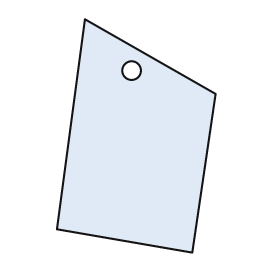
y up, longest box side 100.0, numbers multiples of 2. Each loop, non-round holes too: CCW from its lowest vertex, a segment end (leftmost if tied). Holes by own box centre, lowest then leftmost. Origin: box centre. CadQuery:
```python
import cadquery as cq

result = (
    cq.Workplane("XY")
    .moveTo(24.0, -50.0)
    .lineTo(34.0, 18.0)
    .lineTo(-22.0, 50.0)
    .lineTo(-34.0, -40.0)
    .close()
    .moveTo(-2.0, 28.0)
    .circle(4.0)
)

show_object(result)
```